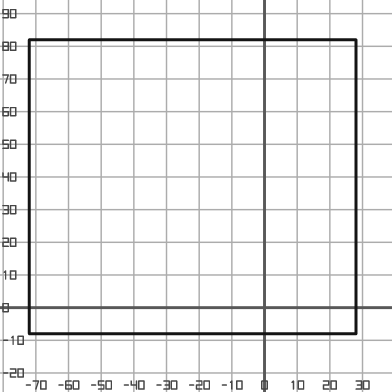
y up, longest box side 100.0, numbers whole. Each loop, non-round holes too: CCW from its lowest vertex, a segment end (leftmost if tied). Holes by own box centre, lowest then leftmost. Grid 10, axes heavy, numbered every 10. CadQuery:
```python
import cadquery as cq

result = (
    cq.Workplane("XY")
    .moveTo(-72.0, -8.0)
    .lineTo(28.0, -8.0)
    .lineTo(28.0, 82.0)
    .lineTo(-72.0, 82.0)
    .close()
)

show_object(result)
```